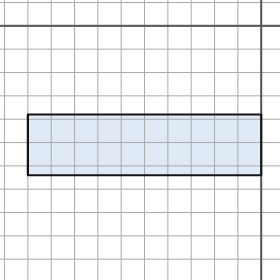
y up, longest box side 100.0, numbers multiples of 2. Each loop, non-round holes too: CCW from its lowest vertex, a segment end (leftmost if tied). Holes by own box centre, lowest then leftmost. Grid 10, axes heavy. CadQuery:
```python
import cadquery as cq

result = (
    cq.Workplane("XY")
    .moveTo(-100.0, -64.0)
    .lineTo(0.0, -64.0)
    .lineTo(0.0, -38.0)
    .lineTo(-100.0, -38.0)
    .close()
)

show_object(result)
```